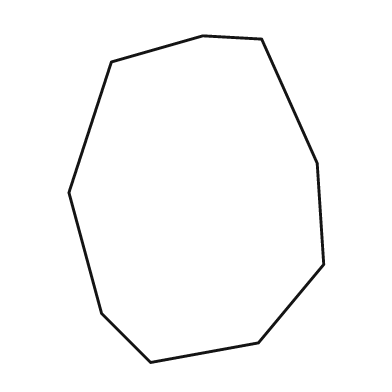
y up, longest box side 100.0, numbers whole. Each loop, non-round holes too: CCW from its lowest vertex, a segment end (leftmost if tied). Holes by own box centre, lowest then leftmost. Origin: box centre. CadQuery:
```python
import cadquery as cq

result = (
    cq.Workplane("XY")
    .moveTo(-14.0, -50.0)
    .lineTo(19.0, -44.0)
    .lineTo(39.0, -20.0)
    .lineTo(37.0, 11.0)
    .lineTo(20.0, 49.0)
    .lineTo(2.0, 50.0)
    .lineTo(-26.0, 42.0)
    .lineTo(-39.0, 2.0)
    .lineTo(-29.0, -35.0)
    .close()
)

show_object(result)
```